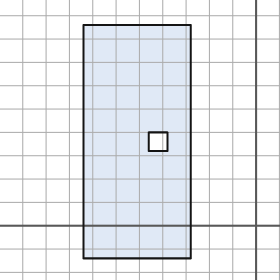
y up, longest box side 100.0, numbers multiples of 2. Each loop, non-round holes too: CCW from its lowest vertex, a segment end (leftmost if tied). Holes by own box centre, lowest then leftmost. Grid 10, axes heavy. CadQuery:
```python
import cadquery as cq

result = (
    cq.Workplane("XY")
    .moveTo(-74.0, -14.0)
    .lineTo(-28.0, -14.0)
    .lineTo(-28.0, 86.0)
    .lineTo(-74.0, 86.0)
    .close()
    .moveTo(-46.0, 32.0)
    .lineTo(-38.0, 32.0)
    .lineTo(-38.0, 40.0)
    .lineTo(-46.0, 40.0)
    .close()
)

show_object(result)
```